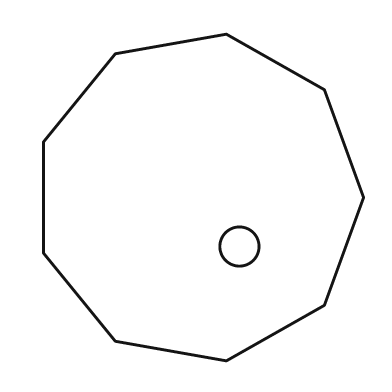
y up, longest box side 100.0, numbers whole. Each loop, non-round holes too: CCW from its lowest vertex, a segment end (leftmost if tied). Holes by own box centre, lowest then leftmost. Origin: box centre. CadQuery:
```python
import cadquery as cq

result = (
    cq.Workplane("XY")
    .moveTo(7.0, -50.0)
    .lineTo(37.0, -33.0)
    .lineTo(49.0, 0.0)
    .lineTo(37.0, 33.0)
    .lineTo(7.0, 50.0)
    .lineTo(-27.0, 44.0)
    .lineTo(-49.0, 17.0)
    .lineTo(-49.0, -17.0)
    .lineTo(-27.0, -44.0)
    .close()
    .moveTo(11.0, -15.0)
    .circle(6.0)
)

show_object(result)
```